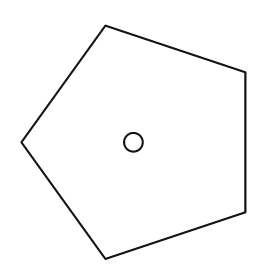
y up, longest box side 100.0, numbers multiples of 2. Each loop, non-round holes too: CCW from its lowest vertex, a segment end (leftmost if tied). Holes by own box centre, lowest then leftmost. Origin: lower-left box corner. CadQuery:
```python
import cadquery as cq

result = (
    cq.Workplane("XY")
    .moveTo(36.0, 0.0)
    .lineTo(96.0, 20.0)
    .lineTo(96.0, 80.0)
    .lineTo(36.0, 100.0)
    .lineTo(0.0, 50.0)
    .close()
    .moveTo(48.0, 50.0)
    .circle(4.0)
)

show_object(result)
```